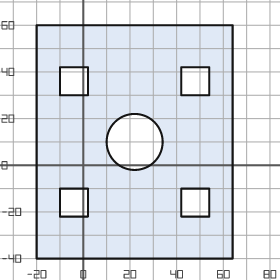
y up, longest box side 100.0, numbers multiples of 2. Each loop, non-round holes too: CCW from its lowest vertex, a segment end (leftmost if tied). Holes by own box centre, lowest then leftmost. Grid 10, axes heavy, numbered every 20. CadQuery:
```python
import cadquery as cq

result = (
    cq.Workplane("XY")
    .moveTo(-20.0, -40.0)
    .lineTo(64.0, -40.0)
    .lineTo(64.0, 60.0)
    .lineTo(-20.0, 60.0)
    .close()
    .moveTo(-10.0, -22.0)
    .lineTo(2.0, -22.0)
    .lineTo(2.0, -10.0)
    .lineTo(-10.0, -10.0)
    .close()
    .moveTo(42.0, -22.0)
    .lineTo(54.0, -22.0)
    .lineTo(54.0, -10.0)
    .lineTo(42.0, -10.0)
    .close()
    .moveTo(22.0, 10.0)
    .circle(12.0)
    .moveTo(-10.0, 30.0)
    .lineTo(2.0, 30.0)
    .lineTo(2.0, 42.0)
    .lineTo(-10.0, 42.0)
    .close()
    .moveTo(42.0, 30.0)
    .lineTo(54.0, 30.0)
    .lineTo(54.0, 42.0)
    .lineTo(42.0, 42.0)
    .close()
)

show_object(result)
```